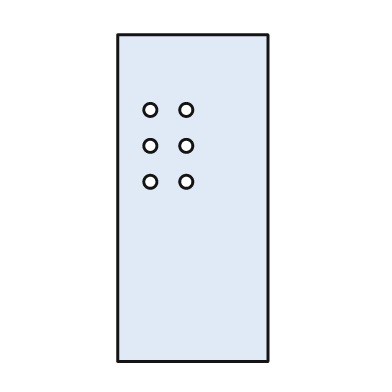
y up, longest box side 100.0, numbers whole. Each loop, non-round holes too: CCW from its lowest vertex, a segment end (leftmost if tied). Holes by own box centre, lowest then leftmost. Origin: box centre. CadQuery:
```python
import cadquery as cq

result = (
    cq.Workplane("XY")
    .moveTo(-23.0, -50.0)
    .lineTo(23.0, -50.0)
    .lineTo(23.0, 50.0)
    .lineTo(-23.0, 50.0)
    .close()
    .moveTo(-13.0, 5.0)
    .circle(2.0)
    .moveTo(-2.0, 5.0)
    .circle(2.0)
    .moveTo(-13.0, 16.0)
    .circle(2.0)
    .moveTo(-2.0, 16.0)
    .circle(2.0)
    .moveTo(-13.0, 27.0)
    .circle(2.0)
    .moveTo(-2.0, 27.0)
    .circle(2.0)
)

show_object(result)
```